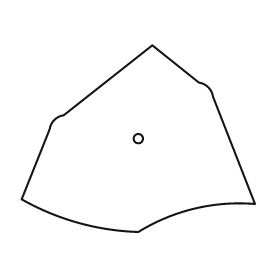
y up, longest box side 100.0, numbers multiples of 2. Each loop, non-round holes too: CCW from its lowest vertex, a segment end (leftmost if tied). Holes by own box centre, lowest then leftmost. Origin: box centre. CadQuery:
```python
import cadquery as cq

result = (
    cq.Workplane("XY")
    .moveTo(0.0, -40.0)
    .threePointArc((24.0, -30.0), (50.0, -28.0))
    .lineTo(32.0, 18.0)
    .threePointArc((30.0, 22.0), (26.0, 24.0))
    .lineTo(6.0, 40.0)
    .lineTo(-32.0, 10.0)
    .threePointArc((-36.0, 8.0), (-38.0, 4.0))
    .lineTo(-50.0, -26.0)
    .threePointArc((-26.0, -36.0), (0.0, -40.0))
    .close()
    .moveTo(0.0, 0.0)
    .circle(2.0)
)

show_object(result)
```